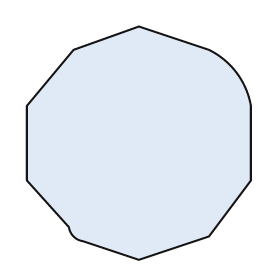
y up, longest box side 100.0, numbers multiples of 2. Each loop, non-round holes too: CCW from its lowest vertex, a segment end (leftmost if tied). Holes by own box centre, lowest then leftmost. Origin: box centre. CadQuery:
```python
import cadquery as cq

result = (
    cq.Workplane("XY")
    .moveTo(0.0, -50.0)
    .lineTo(30.0, -40.0)
    .lineTo(48.0, -16.0)
    .lineTo(48.0, 16.0)
    .threePointArc((42.0, 30.0), (30.0, 40.0))
    .lineTo(0.0, 50.0)
    .lineTo(-28.0, 40.0)
    .lineTo(-48.0, 16.0)
    .lineTo(-48.0, -16.0)
    .lineTo(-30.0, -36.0)
    .threePointArc((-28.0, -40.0), (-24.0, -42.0))
    .close()
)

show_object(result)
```